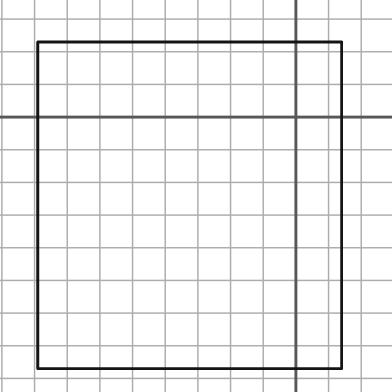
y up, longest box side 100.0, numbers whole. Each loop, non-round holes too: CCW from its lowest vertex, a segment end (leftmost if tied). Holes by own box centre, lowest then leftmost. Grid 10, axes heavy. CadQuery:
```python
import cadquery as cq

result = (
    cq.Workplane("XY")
    .moveTo(-79.0, -77.0)
    .lineTo(14.0, -77.0)
    .lineTo(14.0, 23.0)
    .lineTo(-79.0, 23.0)
    .close()
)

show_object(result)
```